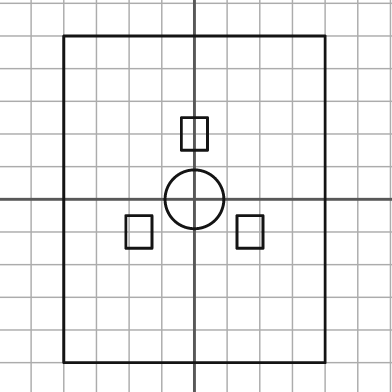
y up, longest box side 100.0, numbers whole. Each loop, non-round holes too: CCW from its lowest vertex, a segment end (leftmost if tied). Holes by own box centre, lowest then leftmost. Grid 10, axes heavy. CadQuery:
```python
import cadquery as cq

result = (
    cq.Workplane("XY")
    .moveTo(-40.0, -50.0)
    .lineTo(40.0, -50.0)
    .lineTo(40.0, 50.0)
    .lineTo(-40.0, 50.0)
    .close()
    .moveTo(-21.0, -15.0)
    .lineTo(-13.0, -15.0)
    .lineTo(-13.0, -5.0)
    .lineTo(-21.0, -5.0)
    .close()
    .moveTo(13.0, -15.0)
    .lineTo(21.0, -15.0)
    .lineTo(21.0, -5.0)
    .lineTo(13.0, -5.0)
    .close()
    .moveTo(0.0, 0.0)
    .circle(9.0)
    .moveTo(-4.0, 15.0)
    .lineTo(4.0, 15.0)
    .lineTo(4.0, 25.0)
    .lineTo(-4.0, 25.0)
    .close()
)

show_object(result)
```